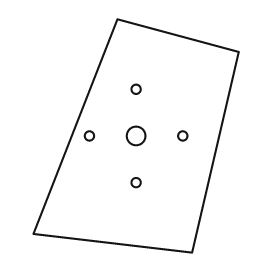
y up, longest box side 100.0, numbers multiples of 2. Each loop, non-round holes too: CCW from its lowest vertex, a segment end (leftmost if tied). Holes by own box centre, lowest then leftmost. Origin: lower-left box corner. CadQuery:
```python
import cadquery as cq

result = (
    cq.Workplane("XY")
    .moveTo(68.0, 0.0)
    .lineTo(88.0, 86.0)
    .lineTo(36.0, 100.0)
    .lineTo(0.0, 8.0)
    .close()
    .moveTo(44.0, 30.0)
    .circle(2.0)
    .moveTo(24.0, 50.0)
    .circle(2.0)
    .moveTo(44.0, 50.0)
    .circle(4.0)
    .moveTo(64.0, 50.0)
    .circle(2.0)
    .moveTo(44.0, 70.0)
    .circle(2.0)
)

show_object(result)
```